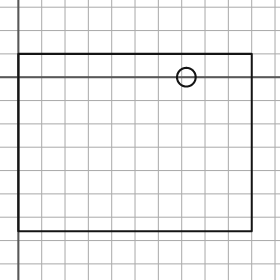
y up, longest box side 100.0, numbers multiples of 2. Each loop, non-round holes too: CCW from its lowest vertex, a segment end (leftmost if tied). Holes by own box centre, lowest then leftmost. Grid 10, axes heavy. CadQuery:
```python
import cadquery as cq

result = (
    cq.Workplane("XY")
    .moveTo(0.0, -66.0)
    .lineTo(100.0, -66.0)
    .lineTo(100.0, 10.0)
    .lineTo(0.0, 10.0)
    .close()
    .moveTo(72.0, 0.0)
    .circle(4.0)
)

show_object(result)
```